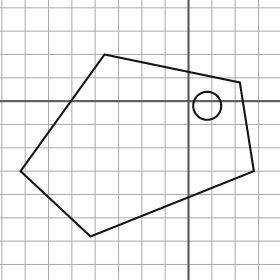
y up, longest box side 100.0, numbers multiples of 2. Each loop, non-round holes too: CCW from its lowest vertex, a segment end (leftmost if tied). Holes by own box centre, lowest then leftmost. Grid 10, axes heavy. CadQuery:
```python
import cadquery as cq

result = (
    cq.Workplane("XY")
    .moveTo(-42.0, -58.0)
    .lineTo(28.0, -30.0)
    .lineTo(22.0, 8.0)
    .lineTo(-36.0, 20.0)
    .lineTo(-72.0, -30.0)
    .close()
    .moveTo(8.0, -2.0)
    .circle(6.0)
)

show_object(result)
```